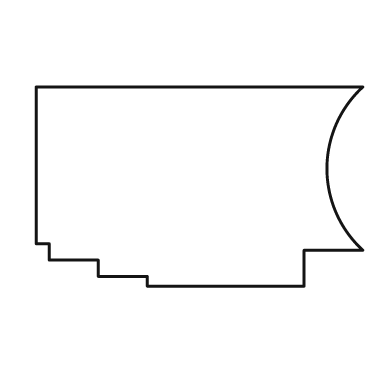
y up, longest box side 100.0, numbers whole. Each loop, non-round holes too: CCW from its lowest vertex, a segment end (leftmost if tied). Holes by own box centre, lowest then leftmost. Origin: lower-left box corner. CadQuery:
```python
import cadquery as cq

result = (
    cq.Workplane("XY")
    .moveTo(34.0, 0.0)
    .lineTo(82.0, 0.0)
    .lineTo(82.0, 11.0)
    .lineTo(100.0, 11.0)
    .threePointArc((89.0, 36.0), (100.0, 61.0))
    .lineTo(0.0, 61.0)
    .lineTo(0.0, 13.0)
    .lineTo(4.0, 13.0)
    .lineTo(4.0, 8.0)
    .lineTo(19.0, 8.0)
    .lineTo(19.0, 3.0)
    .lineTo(34.0, 3.0)
    .close()
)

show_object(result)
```